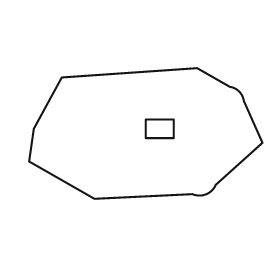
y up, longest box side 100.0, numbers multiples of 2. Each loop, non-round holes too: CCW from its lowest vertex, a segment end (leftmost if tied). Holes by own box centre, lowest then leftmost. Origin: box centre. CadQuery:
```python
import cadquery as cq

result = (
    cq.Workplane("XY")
    .moveTo(-22.0, -28.0)
    .lineTo(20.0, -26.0)
    .threePointArc((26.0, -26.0), (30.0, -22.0))
    .lineTo(50.0, -4.0)
    .lineTo(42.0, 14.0)
    .threePointArc((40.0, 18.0), (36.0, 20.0))
    .lineTo(22.0, 28.0)
    .lineTo(-36.0, 24.0)
    .lineTo(-48.0, 2.0)
    .lineTo(-50.0, -12.0)
    .close()
    .moveTo(0.0, -2.0)
    .lineTo(12.0, -2.0)
    .lineTo(12.0, 6.0)
    .lineTo(0.0, 6.0)
    .close()
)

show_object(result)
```